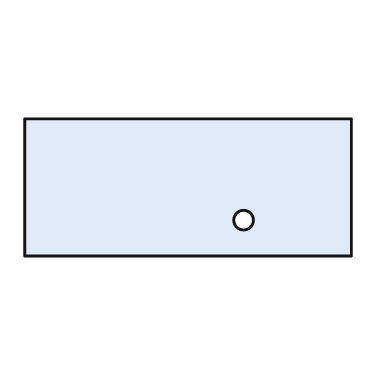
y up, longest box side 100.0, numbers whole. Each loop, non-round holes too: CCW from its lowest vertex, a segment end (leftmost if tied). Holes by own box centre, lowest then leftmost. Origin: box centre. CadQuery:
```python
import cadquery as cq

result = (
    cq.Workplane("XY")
    .moveTo(-50.0, -21.0)
    .lineTo(50.0, -21.0)
    .lineTo(50.0, 21.0)
    .lineTo(-50.0, 21.0)
    .close()
    .moveTo(17.0, -10.0)
    .circle(3.0)
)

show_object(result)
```